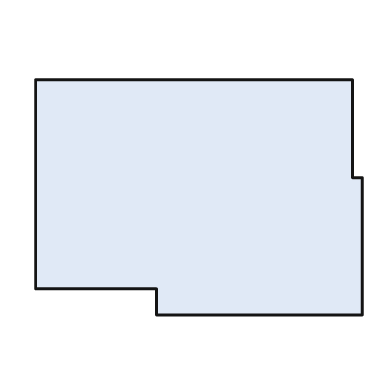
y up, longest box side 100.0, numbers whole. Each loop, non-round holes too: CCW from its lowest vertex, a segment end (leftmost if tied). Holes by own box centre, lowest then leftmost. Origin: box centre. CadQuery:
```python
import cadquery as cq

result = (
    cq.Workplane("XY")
    .moveTo(-13.0, -36.0)
    .lineTo(50.0, -36.0)
    .lineTo(50.0, 6.0)
    .lineTo(47.0, 6.0)
    .lineTo(47.0, 36.0)
    .lineTo(-50.0, 36.0)
    .lineTo(-50.0, -28.0)
    .lineTo(-13.0, -28.0)
    .close()
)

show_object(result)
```